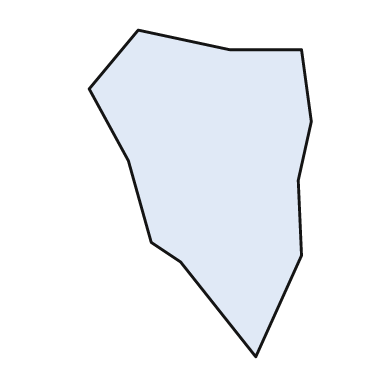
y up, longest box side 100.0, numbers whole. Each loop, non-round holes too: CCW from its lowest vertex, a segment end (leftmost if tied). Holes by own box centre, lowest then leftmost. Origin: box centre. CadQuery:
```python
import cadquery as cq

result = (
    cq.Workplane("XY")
    .moveTo(17.0, -50.0)
    .lineTo(31.0, -19.0)
    .lineTo(30.0, 4.0)
    .lineTo(34.0, 22.0)
    .lineTo(31.0, 44.0)
    .lineTo(9.0, 44.0)
    .lineTo(-19.0, 50.0)
    .lineTo(-34.0, 32.0)
    .lineTo(-22.0, 10.0)
    .lineTo(-15.0, -15.0)
    .lineTo(-6.0, -21.0)
    .close()
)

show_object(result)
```